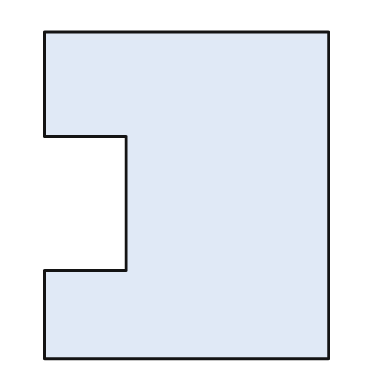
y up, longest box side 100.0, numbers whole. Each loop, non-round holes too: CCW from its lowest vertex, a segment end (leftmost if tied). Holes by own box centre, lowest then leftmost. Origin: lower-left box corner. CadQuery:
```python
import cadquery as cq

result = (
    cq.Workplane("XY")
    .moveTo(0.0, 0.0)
    .lineTo(87.0, 0.0)
    .lineTo(87.0, 100.0)
    .lineTo(0.0, 100.0)
    .lineTo(0.0, 68.0)
    .lineTo(25.0, 68.0)
    .lineTo(25.0, 27.0)
    .lineTo(0.0, 27.0)
    .close()
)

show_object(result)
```